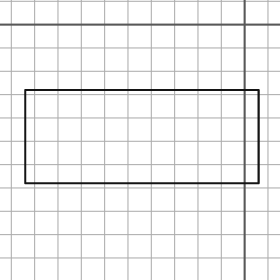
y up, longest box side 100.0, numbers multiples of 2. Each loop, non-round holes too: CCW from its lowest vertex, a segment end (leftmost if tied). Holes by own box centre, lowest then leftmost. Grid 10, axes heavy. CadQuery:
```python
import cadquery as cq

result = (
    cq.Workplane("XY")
    .moveTo(-94.0, -68.0)
    .lineTo(6.0, -68.0)
    .lineTo(6.0, -28.0)
    .lineTo(-94.0, -28.0)
    .close()
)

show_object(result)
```